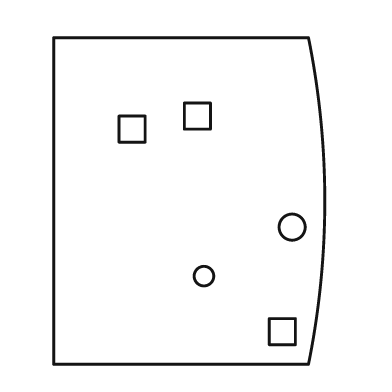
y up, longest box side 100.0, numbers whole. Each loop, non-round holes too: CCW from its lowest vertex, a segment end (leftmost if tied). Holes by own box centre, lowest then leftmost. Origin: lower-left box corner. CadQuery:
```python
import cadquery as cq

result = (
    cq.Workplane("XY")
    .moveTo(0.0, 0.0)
    .lineTo(78.0, 0.0)
    .threePointArc((83.0, 50.0), (78.0, 100.0))
    .lineTo(0.0, 100.0)
    .close()
    .moveTo(66.0, 6.0)
    .lineTo(74.0, 6.0)
    .lineTo(74.0, 14.0)
    .lineTo(66.0, 14.0)
    .close()
    .moveTo(46.0, 27.0)
    .circle(3.0)
    .moveTo(73.0, 42.0)
    .circle(4.0)
    .moveTo(20.0, 68.0)
    .lineTo(28.0, 68.0)
    .lineTo(28.0, 76.0)
    .lineTo(20.0, 76.0)
    .close()
    .moveTo(40.0, 72.0)
    .lineTo(48.0, 72.0)
    .lineTo(48.0, 80.0)
    .lineTo(40.0, 80.0)
    .close()
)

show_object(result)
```